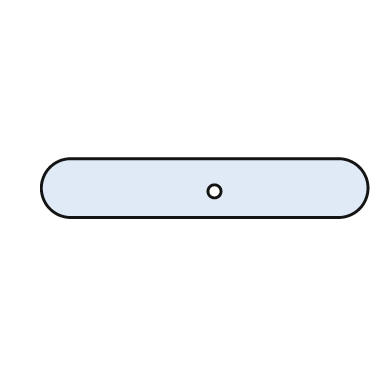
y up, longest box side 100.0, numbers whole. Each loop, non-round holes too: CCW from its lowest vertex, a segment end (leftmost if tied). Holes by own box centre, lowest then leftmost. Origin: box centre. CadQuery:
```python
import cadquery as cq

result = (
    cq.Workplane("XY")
    .moveTo(-41.0, -9.0)
    .lineTo(41.0, -9.0)
    .threePointArc((50.0, 0.0), (41.0, 9.0))
    .lineTo(-41.0, 9.0)
    .threePointArc((-50.0, 0.0), (-41.0, -9.0))
    .close()
    .moveTo(3.0, -1.0)
    .circle(2.0)
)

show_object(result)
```